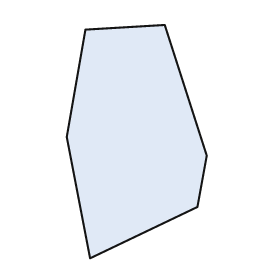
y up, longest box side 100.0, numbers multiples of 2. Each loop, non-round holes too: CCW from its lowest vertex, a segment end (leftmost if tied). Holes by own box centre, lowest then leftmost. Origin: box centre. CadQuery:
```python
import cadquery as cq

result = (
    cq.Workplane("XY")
    .moveTo(-20.0, -50.0)
    .lineTo(26.0, -28.0)
    .lineTo(30.0, -6.0)
    .lineTo(12.0, 50.0)
    .lineTo(-22.0, 48.0)
    .lineTo(-30.0, 2.0)
    .close()
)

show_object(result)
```